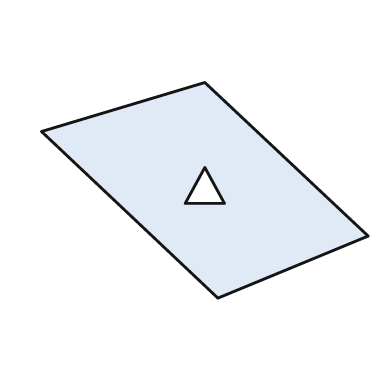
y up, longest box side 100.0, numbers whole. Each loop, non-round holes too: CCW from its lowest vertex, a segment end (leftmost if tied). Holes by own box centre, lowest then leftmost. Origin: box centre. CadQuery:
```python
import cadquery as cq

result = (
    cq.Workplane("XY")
    .moveTo(4.0, -33.0)
    .lineTo(50.0, -14.0)
    .lineTo(0.0, 33.0)
    .lineTo(-50.0, 18.0)
    .close()
    .moveTo(-6.0, -4.0)
    .lineTo(6.0, -4.0)
    .lineTo(0.0, 7.0)
    .close()
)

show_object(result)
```